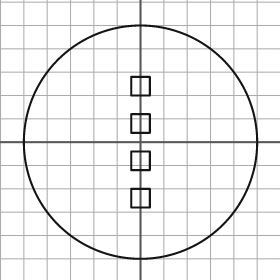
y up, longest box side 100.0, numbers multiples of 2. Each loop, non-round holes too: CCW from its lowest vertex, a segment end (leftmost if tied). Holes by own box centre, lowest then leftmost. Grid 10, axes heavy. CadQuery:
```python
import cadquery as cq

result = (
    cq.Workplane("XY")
    .moveTo(0.0, 0.0)
    .circle(50.0)
    .moveTo(-4.0, -28.0)
    .lineTo(4.0, -28.0)
    .lineTo(4.0, -20.0)
    .lineTo(-4.0, -20.0)
    .close()
    .moveTo(-4.0, -12.0)
    .lineTo(4.0, -12.0)
    .lineTo(4.0, -4.0)
    .lineTo(-4.0, -4.0)
    .close()
    .moveTo(-4.0, 4.0)
    .lineTo(4.0, 4.0)
    .lineTo(4.0, 12.0)
    .lineTo(-4.0, 12.0)
    .close()
    .moveTo(-4.0, 20.0)
    .lineTo(4.0, 20.0)
    .lineTo(4.0, 28.0)
    .lineTo(-4.0, 28.0)
    .close()
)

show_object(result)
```